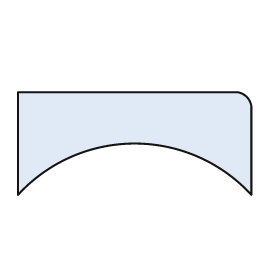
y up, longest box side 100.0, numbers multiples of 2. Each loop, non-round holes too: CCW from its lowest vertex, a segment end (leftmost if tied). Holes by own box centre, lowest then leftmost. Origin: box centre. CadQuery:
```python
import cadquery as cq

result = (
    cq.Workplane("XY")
    .moveTo(-50.0, -22.0)
    .threePointArc((0.0, 0.0), (50.0, -22.0))
    .lineTo(50.0, 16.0)
    .threePointArc((48.0, 20.0), (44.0, 22.0))
    .lineTo(-50.0, 22.0)
    .close()
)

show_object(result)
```